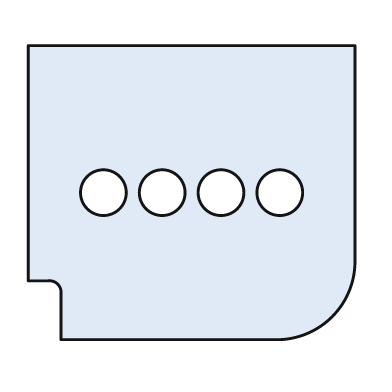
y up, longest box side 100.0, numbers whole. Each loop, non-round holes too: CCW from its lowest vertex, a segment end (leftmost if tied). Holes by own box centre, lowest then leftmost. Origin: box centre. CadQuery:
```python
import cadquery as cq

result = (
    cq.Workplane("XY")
    .moveTo(-40.0, -45.0)
    .lineTo(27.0, -45.0)
    .threePointArc((43.0, -38.0), (50.0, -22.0))
    .lineTo(50.0, 45.0)
    .lineTo(-50.0, 45.0)
    .lineTo(-50.0, -27.0)
    .lineTo(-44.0, -27.0)
    .threePointArc((-41.0, -28.0), (-40.0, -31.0))
    .close()
    .moveTo(-27.0, 0.0)
    .circle(7.0)
    .moveTo(-9.0, 0.0)
    .circle(7.0)
    .moveTo(9.0, 0.0)
    .circle(7.0)
    .moveTo(27.0, 0.0)
    .circle(7.0)
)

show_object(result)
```